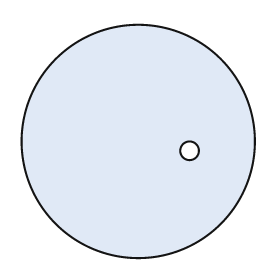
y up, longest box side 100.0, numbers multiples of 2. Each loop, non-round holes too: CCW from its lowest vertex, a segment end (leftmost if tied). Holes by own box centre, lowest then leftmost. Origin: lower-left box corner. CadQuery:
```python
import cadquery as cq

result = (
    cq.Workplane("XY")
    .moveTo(50.0, 50.0)
    .circle(50.0)
    .moveTo(72.0, 46.0)
    .circle(4.0)
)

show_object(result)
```